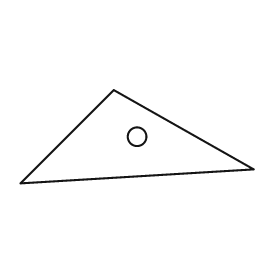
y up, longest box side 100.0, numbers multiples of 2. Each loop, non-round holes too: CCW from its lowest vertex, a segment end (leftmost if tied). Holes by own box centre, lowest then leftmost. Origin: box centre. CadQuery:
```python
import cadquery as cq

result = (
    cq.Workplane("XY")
    .moveTo(-50.0, -20.0)
    .lineTo(50.0, -14.0)
    .lineTo(-10.0, 20.0)
    .close()
    .moveTo(0.0, 0.0)
    .circle(4.0)
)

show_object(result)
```